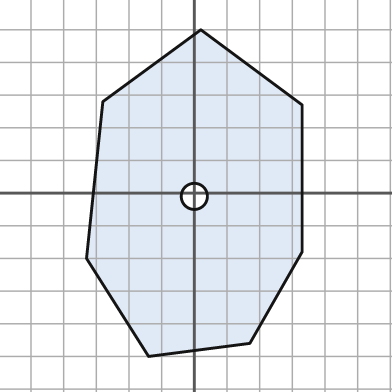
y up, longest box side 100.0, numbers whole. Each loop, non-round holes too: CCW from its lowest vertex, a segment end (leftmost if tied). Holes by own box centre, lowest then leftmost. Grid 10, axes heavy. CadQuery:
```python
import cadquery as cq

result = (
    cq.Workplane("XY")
    .moveTo(-14.0, -50.0)
    .lineTo(17.0, -46.0)
    .lineTo(33.0, -18.0)
    .lineTo(33.0, 27.0)
    .lineTo(2.0, 50.0)
    .lineTo(-28.0, 28.0)
    .lineTo(-33.0, -20.0)
    .close()
    .moveTo(0.0, -1.0)
    .circle(4.0)
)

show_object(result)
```